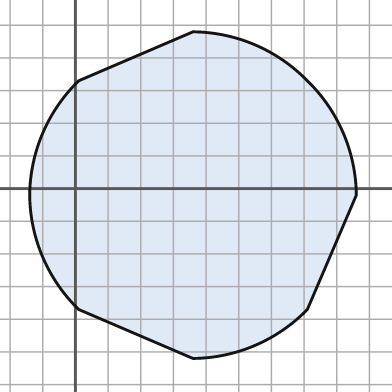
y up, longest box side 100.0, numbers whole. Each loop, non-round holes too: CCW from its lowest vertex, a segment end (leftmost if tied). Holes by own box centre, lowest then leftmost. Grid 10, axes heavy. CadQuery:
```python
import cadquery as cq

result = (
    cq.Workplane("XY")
    .moveTo(36.0, -52.0)
    .threePointArc((55.0, -48.0), (71.0, -37.0))
    .lineTo(86.0, -2.0)
    .threePointArc((82.0, 17.0), (71.0, 33.0))
    .threePointArc((55.0, 44.0), (36.0, 48.0))
    .lineTo(1.0, 33.0)
    .threePointArc((-10.0, 17.0), (-14.0, -2.0))
    .threePointArc((-10.0, -21.0), (1.0, -37.0))
    .close()
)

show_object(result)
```